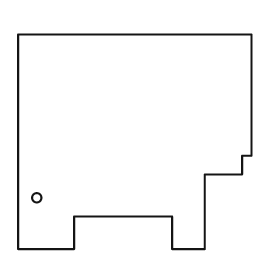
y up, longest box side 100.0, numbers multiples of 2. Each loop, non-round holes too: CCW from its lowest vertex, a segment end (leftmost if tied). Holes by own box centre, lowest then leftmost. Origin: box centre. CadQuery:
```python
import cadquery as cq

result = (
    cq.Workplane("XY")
    .moveTo(-50.0, -46.0)
    .lineTo(-26.0, -46.0)
    .lineTo(-26.0, -32.0)
    .lineTo(16.0, -32.0)
    .lineTo(16.0, -46.0)
    .lineTo(30.0, -46.0)
    .lineTo(30.0, -14.0)
    .lineTo(46.0, -14.0)
    .lineTo(46.0, -6.0)
    .lineTo(50.0, -6.0)
    .lineTo(50.0, 46.0)
    .lineTo(-50.0, 46.0)
    .close()
    .moveTo(-42.0, -24.0)
    .circle(2.0)
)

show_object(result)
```